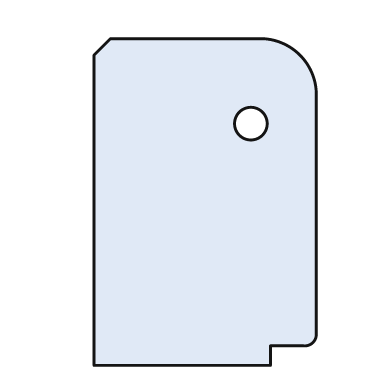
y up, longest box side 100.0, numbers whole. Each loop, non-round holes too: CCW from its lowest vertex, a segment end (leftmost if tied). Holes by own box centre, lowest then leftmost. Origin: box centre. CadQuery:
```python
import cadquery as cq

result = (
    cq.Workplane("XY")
    .moveTo(-34.0, -50.0)
    .lineTo(20.0, -50.0)
    .lineTo(20.0, -44.0)
    .lineTo(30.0, -44.0)
    .threePointArc((33.0, -43.0), (34.0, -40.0))
    .lineTo(34.0, 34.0)
    .threePointArc((29.0, 45.0), (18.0, 50.0))
    .lineTo(-29.0, 50.0)
    .lineTo(-34.0, 45.0)
    .close()
    .moveTo(14.0, 24.0)
    .circle(5.0)
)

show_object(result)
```